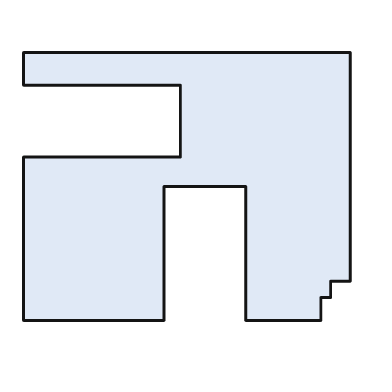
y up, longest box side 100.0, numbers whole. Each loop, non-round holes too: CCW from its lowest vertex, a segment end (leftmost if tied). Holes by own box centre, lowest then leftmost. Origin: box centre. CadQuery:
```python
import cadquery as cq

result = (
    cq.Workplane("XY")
    .moveTo(-50.0, -41.0)
    .lineTo(-7.0, -41.0)
    .lineTo(-7.0, 0.0)
    .lineTo(18.0, 0.0)
    .lineTo(18.0, -41.0)
    .lineTo(41.0, -41.0)
    .lineTo(41.0, -34.0)
    .lineTo(44.0, -34.0)
    .lineTo(44.0, -29.0)
    .lineTo(50.0, -29.0)
    .lineTo(50.0, 41.0)
    .lineTo(-50.0, 41.0)
    .lineTo(-50.0, 31.0)
    .lineTo(-2.0, 31.0)
    .lineTo(-2.0, 9.0)
    .lineTo(-50.0, 9.0)
    .close()
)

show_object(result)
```